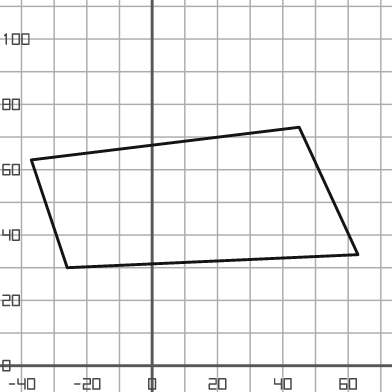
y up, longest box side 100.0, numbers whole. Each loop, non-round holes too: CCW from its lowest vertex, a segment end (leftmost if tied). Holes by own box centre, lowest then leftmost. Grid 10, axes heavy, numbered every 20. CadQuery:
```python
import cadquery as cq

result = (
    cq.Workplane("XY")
    .moveTo(-26.0, 30.0)
    .lineTo(63.0, 34.0)
    .lineTo(45.0, 73.0)
    .lineTo(-37.0, 63.0)
    .close()
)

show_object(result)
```